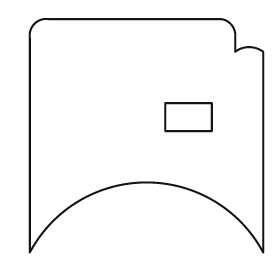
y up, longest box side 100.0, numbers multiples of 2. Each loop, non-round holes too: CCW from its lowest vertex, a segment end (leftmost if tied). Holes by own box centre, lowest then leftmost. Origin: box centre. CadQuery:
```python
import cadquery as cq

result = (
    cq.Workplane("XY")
    .moveTo(-50.0, -50.0)
    .threePointArc((0.0, -20.0), (50.0, -50.0))
    .lineTo(50.0, 36.0)
    .threePointArc((44.0, 38.0), (38.0, 36.0))
    .lineTo(38.0, 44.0)
    .threePointArc((36.0, 48.0), (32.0, 50.0))
    .lineTo(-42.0, 50.0)
    .threePointArc((-48.0, 48.0), (-50.0, 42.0))
    .close()
    .moveTo(8.0, 2.0)
    .lineTo(28.0, 2.0)
    .lineTo(28.0, 14.0)
    .lineTo(8.0, 14.0)
    .close()
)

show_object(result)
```